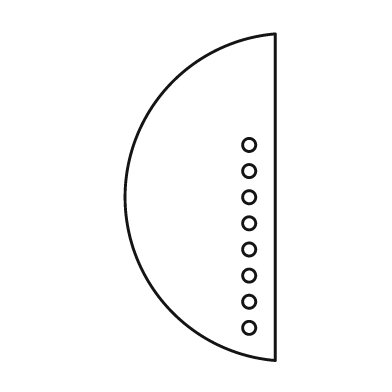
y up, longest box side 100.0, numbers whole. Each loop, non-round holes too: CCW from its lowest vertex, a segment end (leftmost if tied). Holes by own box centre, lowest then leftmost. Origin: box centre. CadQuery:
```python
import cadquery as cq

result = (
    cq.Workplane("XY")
    .moveTo(23.0, -50.0)
    .lineTo(23.0, 50.0)
    .threePointArc((-23.0, 0.0), (23.0, -50.0))
    .close()
    .moveTo(15.0, -40.0)
    .circle(2.0)
    .moveTo(15.0, -32.0)
    .circle(2.0)
    .moveTo(15.0, -24.0)
    .circle(2.0)
    .moveTo(15.0, -16.0)
    .circle(2.0)
    .moveTo(15.0, -8.0)
    .circle(2.0)
    .moveTo(15.0, 0.0)
    .circle(2.0)
    .moveTo(15.0, 8.0)
    .circle(2.0)
    .moveTo(15.0, 16.0)
    .circle(2.0)
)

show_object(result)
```